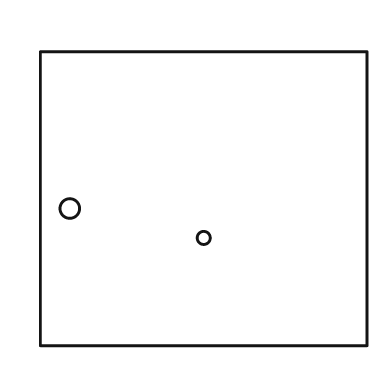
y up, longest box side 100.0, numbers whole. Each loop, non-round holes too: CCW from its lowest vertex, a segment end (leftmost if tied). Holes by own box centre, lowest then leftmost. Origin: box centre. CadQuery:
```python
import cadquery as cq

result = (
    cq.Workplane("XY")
    .moveTo(-50.0, -45.0)
    .lineTo(50.0, -45.0)
    .lineTo(50.0, 45.0)
    .lineTo(-50.0, 45.0)
    .close()
    .moveTo(0.0, -12.0)
    .circle(2.0)
    .moveTo(-41.0, -3.0)
    .circle(3.0)
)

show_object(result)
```